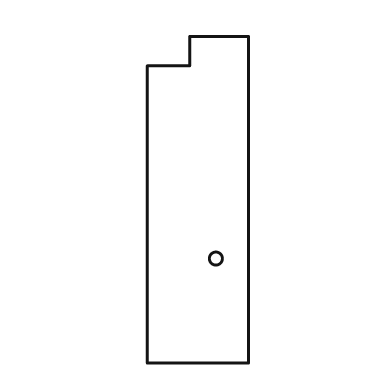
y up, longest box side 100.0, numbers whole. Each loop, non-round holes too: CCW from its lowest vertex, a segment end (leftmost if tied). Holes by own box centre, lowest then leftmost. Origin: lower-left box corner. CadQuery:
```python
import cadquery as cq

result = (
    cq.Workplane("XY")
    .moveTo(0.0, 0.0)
    .lineTo(31.0, 0.0)
    .lineTo(31.0, 100.0)
    .lineTo(13.0, 100.0)
    .lineTo(13.0, 91.0)
    .lineTo(0.0, 91.0)
    .close()
    .moveTo(21.0, 32.0)
    .circle(2.0)
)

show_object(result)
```